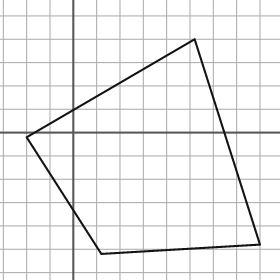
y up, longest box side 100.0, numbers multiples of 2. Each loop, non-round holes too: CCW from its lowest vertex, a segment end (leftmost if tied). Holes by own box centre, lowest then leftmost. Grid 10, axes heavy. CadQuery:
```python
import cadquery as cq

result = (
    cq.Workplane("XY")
    .moveTo(12.0, -52.0)
    .lineTo(80.0, -48.0)
    .lineTo(52.0, 40.0)
    .lineTo(-20.0, -2.0)
    .close()
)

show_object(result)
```